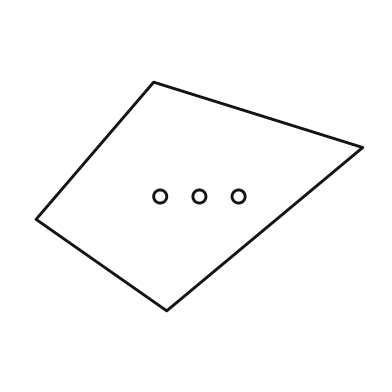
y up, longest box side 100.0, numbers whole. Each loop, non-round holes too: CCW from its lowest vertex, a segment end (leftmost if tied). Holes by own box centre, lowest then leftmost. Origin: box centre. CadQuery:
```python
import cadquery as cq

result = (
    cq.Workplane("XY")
    .moveTo(-10.0, -35.0)
    .lineTo(50.0, 15.0)
    .lineTo(-14.0, 35.0)
    .lineTo(-50.0, -7.0)
    .close()
    .moveTo(-12.0, 0.0)
    .circle(2.0)
    .moveTo(0.0, 0.0)
    .circle(2.0)
    .moveTo(12.0, 0.0)
    .circle(2.0)
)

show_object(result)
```